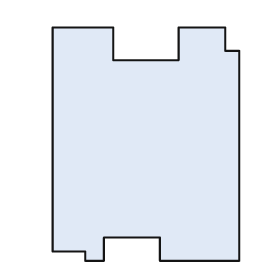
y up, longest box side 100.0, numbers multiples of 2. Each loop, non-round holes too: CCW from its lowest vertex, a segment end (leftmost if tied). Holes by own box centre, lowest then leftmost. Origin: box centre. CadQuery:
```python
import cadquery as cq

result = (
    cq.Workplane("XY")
    .moveTo(-26.0, -50.0)
    .lineTo(-18.0, -50.0)
    .lineTo(-18.0, -40.0)
    .lineTo(6.0, -40.0)
    .lineTo(6.0, -50.0)
    .lineTo(40.0, -50.0)
    .lineTo(40.0, 40.0)
    .lineTo(34.0, 40.0)
    .lineTo(34.0, 50.0)
    .lineTo(14.0, 50.0)
    .lineTo(14.0, 36.0)
    .lineTo(-14.0, 36.0)
    .lineTo(-14.0, 50.0)
    .lineTo(-40.0, 50.0)
    .lineTo(-40.0, -46.0)
    .lineTo(-26.0, -46.0)
    .close()
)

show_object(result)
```